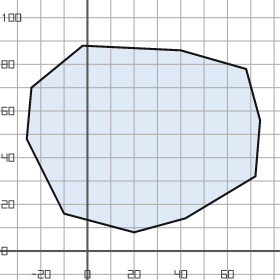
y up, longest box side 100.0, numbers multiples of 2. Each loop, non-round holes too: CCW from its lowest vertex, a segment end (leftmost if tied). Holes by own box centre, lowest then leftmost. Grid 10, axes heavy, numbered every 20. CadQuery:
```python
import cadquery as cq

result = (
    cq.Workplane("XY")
    .moveTo(20.0, 8.0)
    .lineTo(42.0, 14.0)
    .lineTo(72.0, 32.0)
    .lineTo(74.0, 56.0)
    .lineTo(68.0, 78.0)
    .lineTo(40.0, 86.0)
    .lineTo(-2.0, 88.0)
    .lineTo(-24.0, 70.0)
    .lineTo(-26.0, 48.0)
    .lineTo(-10.0, 16.0)
    .close()
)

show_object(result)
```